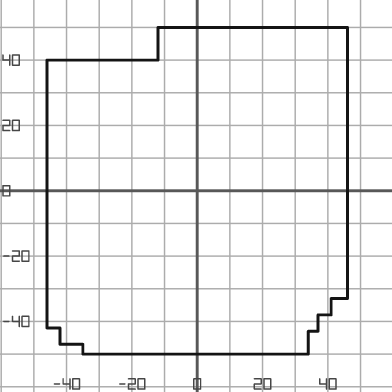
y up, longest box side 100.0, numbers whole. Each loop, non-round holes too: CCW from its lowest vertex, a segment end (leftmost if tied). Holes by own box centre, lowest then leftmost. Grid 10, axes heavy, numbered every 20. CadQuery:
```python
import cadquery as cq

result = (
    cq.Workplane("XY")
    .moveTo(-35.0, -50.0)
    .lineTo(34.0, -50.0)
    .lineTo(34.0, -43.0)
    .lineTo(37.0, -43.0)
    .lineTo(37.0, -38.0)
    .lineTo(41.0, -38.0)
    .lineTo(41.0, -33.0)
    .lineTo(46.0, -33.0)
    .lineTo(46.0, 50.0)
    .lineTo(-12.0, 50.0)
    .lineTo(-12.0, 40.0)
    .lineTo(-46.0, 40.0)
    .lineTo(-46.0, -42.0)
    .lineTo(-42.0, -42.0)
    .lineTo(-42.0, -47.0)
    .lineTo(-35.0, -47.0)
    .close()
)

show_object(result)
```